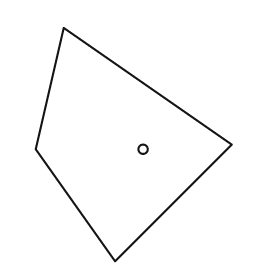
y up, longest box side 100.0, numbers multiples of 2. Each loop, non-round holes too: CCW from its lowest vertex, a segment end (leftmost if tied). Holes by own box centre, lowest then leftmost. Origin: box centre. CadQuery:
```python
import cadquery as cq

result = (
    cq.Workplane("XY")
    .moveTo(-8.0, -50.0)
    .lineTo(42.0, 0.0)
    .lineTo(-30.0, 50.0)
    .lineTo(-42.0, -2.0)
    .close()
    .moveTo(4.0, -2.0)
    .circle(2.0)
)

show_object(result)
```